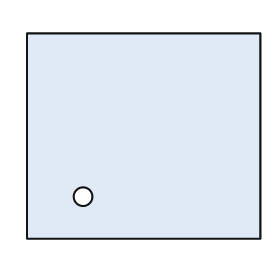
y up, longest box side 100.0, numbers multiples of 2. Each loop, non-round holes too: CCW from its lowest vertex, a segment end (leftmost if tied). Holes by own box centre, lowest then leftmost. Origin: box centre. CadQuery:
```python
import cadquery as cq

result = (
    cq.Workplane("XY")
    .moveTo(-50.0, -44.0)
    .lineTo(50.0, -44.0)
    .lineTo(50.0, 44.0)
    .lineTo(-50.0, 44.0)
    .close()
    .moveTo(-26.0, -26.0)
    .circle(4.0)
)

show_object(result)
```